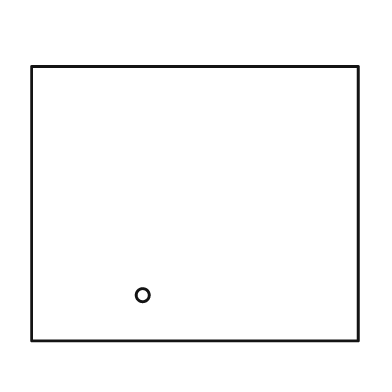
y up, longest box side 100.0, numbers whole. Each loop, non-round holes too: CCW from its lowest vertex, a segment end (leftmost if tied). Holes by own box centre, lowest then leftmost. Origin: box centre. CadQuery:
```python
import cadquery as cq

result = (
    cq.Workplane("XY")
    .moveTo(-50.0, -42.0)
    .lineTo(50.0, -42.0)
    .lineTo(50.0, 42.0)
    .lineTo(-50.0, 42.0)
    .close()
    .moveTo(-16.0, -28.0)
    .circle(2.0)
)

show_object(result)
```